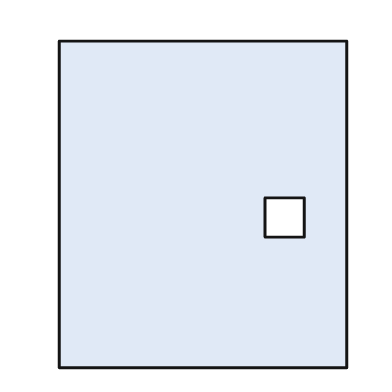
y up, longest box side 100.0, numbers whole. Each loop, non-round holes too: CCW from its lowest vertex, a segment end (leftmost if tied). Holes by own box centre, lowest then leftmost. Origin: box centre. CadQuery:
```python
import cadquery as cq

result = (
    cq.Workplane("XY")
    .moveTo(-44.0, -50.0)
    .lineTo(44.0, -50.0)
    .lineTo(44.0, 50.0)
    .lineTo(-44.0, 50.0)
    .close()
    .moveTo(19.0, -10.0)
    .lineTo(31.0, -10.0)
    .lineTo(31.0, 2.0)
    .lineTo(19.0, 2.0)
    .close()
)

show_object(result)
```